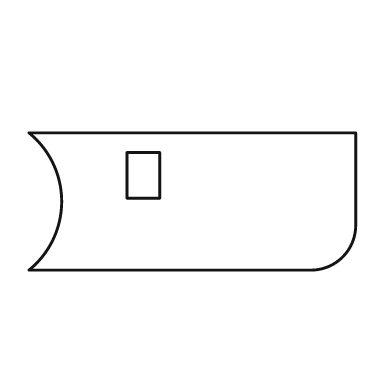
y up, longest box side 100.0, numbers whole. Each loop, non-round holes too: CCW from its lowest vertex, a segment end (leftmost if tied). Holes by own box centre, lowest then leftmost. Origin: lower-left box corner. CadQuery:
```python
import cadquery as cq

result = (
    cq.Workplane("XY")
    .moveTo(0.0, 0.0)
    .lineTo(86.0, 0.0)
    .threePointArc((96.0, 4.0), (100.0, 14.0))
    .lineTo(100.0, 42.0)
    .lineTo(0.0, 42.0)
    .threePointArc((10.0, 21.0), (0.0, 0.0))
    .close()
    .moveTo(30.0, 22.0)
    .lineTo(40.0, 22.0)
    .lineTo(40.0, 36.0)
    .lineTo(30.0, 36.0)
    .close()
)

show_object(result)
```